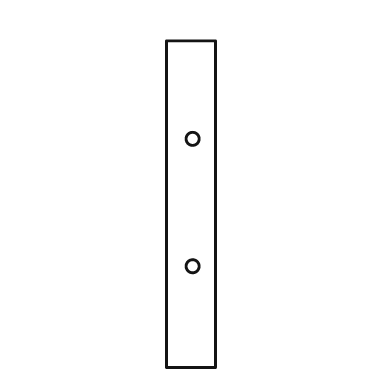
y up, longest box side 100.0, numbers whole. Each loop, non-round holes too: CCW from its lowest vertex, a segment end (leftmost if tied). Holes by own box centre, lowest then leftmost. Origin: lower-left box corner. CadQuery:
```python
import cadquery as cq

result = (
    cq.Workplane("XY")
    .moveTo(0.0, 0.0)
    .lineTo(15.0, 0.0)
    .lineTo(15.0, 100.0)
    .lineTo(0.0, 100.0)
    .close()
    .moveTo(8.0, 31.0)
    .circle(2.0)
    .moveTo(8.0, 70.0)
    .circle(2.0)
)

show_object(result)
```